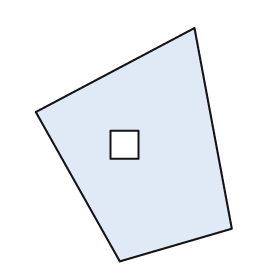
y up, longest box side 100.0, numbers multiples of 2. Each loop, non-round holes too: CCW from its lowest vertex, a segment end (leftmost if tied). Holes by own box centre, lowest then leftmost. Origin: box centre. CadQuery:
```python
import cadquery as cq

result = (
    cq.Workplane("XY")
    .moveTo(-6.0, -50.0)
    .lineTo(42.0, -36.0)
    .lineTo(26.0, 50.0)
    .lineTo(-42.0, 14.0)
    .close()
    .moveTo(-10.0, -6.0)
    .lineTo(2.0, -6.0)
    .lineTo(2.0, 6.0)
    .lineTo(-10.0, 6.0)
    .close()
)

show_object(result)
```